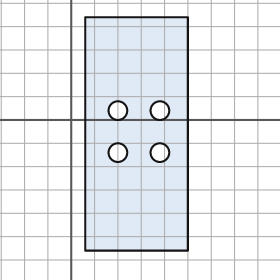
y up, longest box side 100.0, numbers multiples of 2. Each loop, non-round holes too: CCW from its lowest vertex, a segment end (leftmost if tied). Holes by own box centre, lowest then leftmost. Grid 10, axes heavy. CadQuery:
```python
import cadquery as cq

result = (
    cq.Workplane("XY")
    .moveTo(6.0, -56.0)
    .lineTo(50.0, -56.0)
    .lineTo(50.0, 44.0)
    .lineTo(6.0, 44.0)
    .close()
    .moveTo(20.0, -14.0)
    .circle(4.0)
    .moveTo(38.0, -14.0)
    .circle(4.0)
    .moveTo(20.0, 4.0)
    .circle(4.0)
    .moveTo(38.0, 4.0)
    .circle(4.0)
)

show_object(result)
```